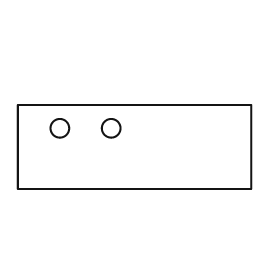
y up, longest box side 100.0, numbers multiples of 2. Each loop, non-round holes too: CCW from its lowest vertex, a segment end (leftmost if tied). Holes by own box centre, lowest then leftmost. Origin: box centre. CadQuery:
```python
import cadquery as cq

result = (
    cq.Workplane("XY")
    .moveTo(-50.0, -18.0)
    .lineTo(50.0, -18.0)
    .lineTo(50.0, 18.0)
    .lineTo(-50.0, 18.0)
    .close()
    .moveTo(-32.0, 8.0)
    .circle(4.0)
    .moveTo(-10.0, 8.0)
    .circle(4.0)
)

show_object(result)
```